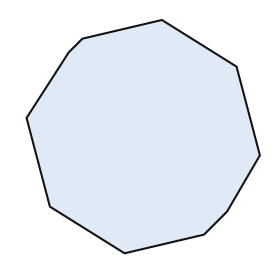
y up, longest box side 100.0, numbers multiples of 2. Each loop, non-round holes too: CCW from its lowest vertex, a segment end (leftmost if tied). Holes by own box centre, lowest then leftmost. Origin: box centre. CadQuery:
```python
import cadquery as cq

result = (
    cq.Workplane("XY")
    .moveTo(-8.0, -50.0)
    .lineTo(26.0, -42.0)
    .lineTo(36.0, -32.0)
    .lineTo(50.0, -8.0)
    .lineTo(40.0, 30.0)
    .lineTo(8.0, 50.0)
    .lineTo(-26.0, 42.0)
    .lineTo(-32.0, 36.0)
    .lineTo(-50.0, 8.0)
    .lineTo(-40.0, -30.0)
    .close()
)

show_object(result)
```